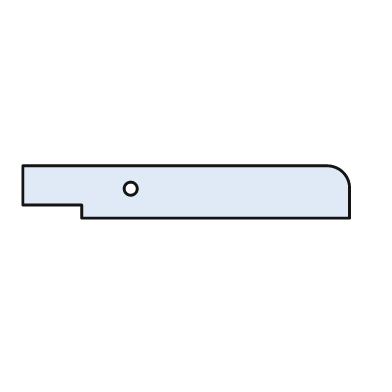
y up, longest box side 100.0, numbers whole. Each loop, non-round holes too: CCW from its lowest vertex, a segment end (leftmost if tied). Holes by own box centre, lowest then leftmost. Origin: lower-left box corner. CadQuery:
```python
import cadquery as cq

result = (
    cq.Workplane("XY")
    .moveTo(18.0, 0.0)
    .lineTo(100.0, 0.0)
    .lineTo(100.0, 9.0)
    .threePointArc((98.0, 14.0), (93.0, 16.0))
    .lineTo(0.0, 16.0)
    .lineTo(0.0, 4.0)
    .lineTo(18.0, 4.0)
    .close()
    .moveTo(33.0, 9.0)
    .circle(2.0)
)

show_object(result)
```